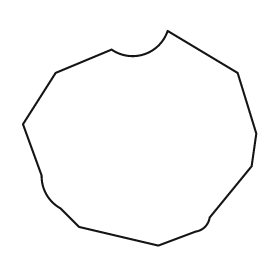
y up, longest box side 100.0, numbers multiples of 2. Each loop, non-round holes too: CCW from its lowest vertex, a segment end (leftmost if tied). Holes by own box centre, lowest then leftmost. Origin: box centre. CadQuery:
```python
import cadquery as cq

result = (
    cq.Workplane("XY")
    .moveTo(8.0, -46.0)
    .lineTo(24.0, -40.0)
    .threePointArc((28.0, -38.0), (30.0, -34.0))
    .lineTo(48.0, -12.0)
    .lineTo(50.0, 2.0)
    .lineTo(42.0, 28.0)
    .lineTo(12.0, 46.0)
    .threePointArc((2.0, 36.0), (-12.0, 38.0))
    .lineTo(-36.0, 28.0)
    .lineTo(-50.0, 6.0)
    .lineTo(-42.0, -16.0)
    .threePointArc((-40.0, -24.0), (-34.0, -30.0))
    .lineTo(-26.0, -38.0)
    .close()
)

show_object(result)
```